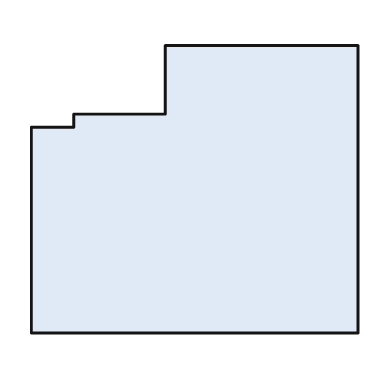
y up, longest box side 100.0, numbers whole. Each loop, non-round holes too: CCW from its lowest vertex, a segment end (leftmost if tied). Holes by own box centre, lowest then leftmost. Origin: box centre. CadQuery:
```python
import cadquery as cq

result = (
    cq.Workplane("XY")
    .moveTo(-50.0, -44.0)
    .lineTo(50.0, -44.0)
    .lineTo(50.0, 44.0)
    .lineTo(-9.0, 44.0)
    .lineTo(-9.0, 23.0)
    .lineTo(-37.0, 23.0)
    .lineTo(-37.0, 19.0)
    .lineTo(-50.0, 19.0)
    .close()
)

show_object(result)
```